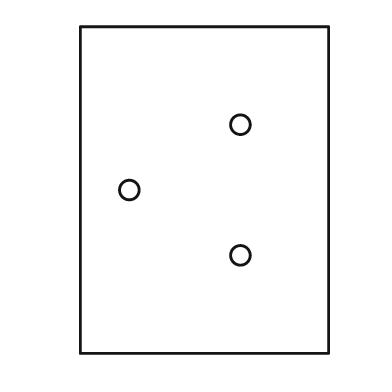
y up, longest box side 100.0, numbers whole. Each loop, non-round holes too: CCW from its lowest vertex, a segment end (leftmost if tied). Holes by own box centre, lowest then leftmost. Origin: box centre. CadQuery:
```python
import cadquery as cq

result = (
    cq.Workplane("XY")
    .moveTo(-38.0, -50.0)
    .lineTo(38.0, -50.0)
    .lineTo(38.0, 50.0)
    .lineTo(-38.0, 50.0)
    .close()
    .moveTo(11.0, -20.0)
    .circle(3.0)
    .moveTo(-23.0, 0.0)
    .circle(3.0)
    .moveTo(11.0, 20.0)
    .circle(3.0)
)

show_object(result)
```